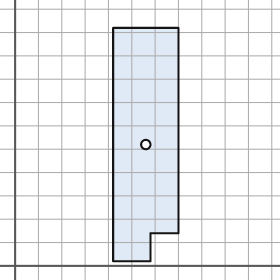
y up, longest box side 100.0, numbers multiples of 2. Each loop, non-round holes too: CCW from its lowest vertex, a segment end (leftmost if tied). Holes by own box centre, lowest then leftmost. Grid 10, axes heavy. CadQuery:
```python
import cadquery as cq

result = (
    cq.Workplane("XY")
    .moveTo(42.0, 2.0)
    .lineTo(58.0, 2.0)
    .lineTo(58.0, 14.0)
    .lineTo(70.0, 14.0)
    .lineTo(70.0, 102.0)
    .lineTo(42.0, 102.0)
    .close()
    .moveTo(56.0, 52.0)
    .circle(2.0)
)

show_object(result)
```